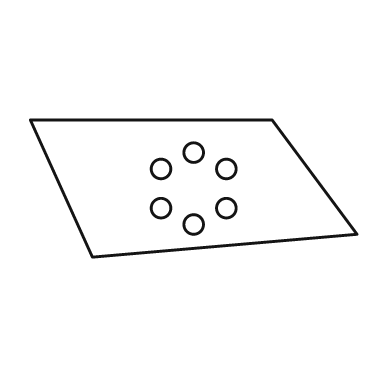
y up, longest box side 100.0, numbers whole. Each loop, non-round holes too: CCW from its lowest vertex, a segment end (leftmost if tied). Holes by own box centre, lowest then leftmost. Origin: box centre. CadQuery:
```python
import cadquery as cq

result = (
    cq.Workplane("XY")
    .moveTo(-31.0, -21.0)
    .lineTo(50.0, -14.0)
    .lineTo(24.0, 21.0)
    .lineTo(-50.0, 21.0)
    .close()
    .moveTo(0.0, -11.0)
    .circle(3.0)
    .moveTo(-10.0, -6.0)
    .circle(3.0)
    .moveTo(10.0, -6.0)
    .circle(3.0)
    .moveTo(-10.0, 6.0)
    .circle(3.0)
    .moveTo(10.0, 6.0)
    .circle(3.0)
    .moveTo(0.0, 11.0)
    .circle(3.0)
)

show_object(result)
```